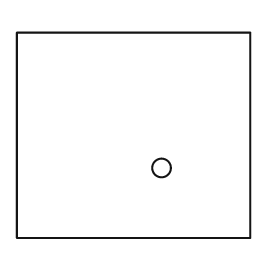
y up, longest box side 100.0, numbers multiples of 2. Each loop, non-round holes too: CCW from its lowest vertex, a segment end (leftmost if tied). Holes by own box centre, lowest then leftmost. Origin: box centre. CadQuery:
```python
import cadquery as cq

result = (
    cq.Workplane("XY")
    .moveTo(-50.0, -44.0)
    .lineTo(50.0, -44.0)
    .lineTo(50.0, 44.0)
    .lineTo(-50.0, 44.0)
    .close()
    .moveTo(12.0, -14.0)
    .circle(4.0)
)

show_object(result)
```